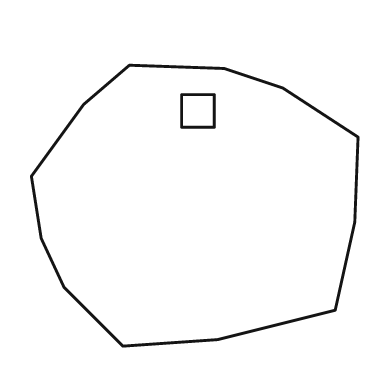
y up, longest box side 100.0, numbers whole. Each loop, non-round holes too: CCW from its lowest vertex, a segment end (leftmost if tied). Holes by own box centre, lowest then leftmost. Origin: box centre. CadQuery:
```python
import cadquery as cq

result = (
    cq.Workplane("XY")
    .moveTo(-22.0, -43.0)
    .lineTo(7.0, -41.0)
    .lineTo(43.0, -32.0)
    .lineTo(49.0, -5.0)
    .lineTo(50.0, 21.0)
    .lineTo(27.0, 36.0)
    .lineTo(9.0, 42.0)
    .lineTo(-20.0, 43.0)
    .lineTo(-34.0, 31.0)
    .lineTo(-50.0, 9.0)
    .lineTo(-47.0, -10.0)
    .lineTo(-40.0, -25.0)
    .close()
    .moveTo(-4.0, 24.0)
    .lineTo(6.0, 24.0)
    .lineTo(6.0, 34.0)
    .lineTo(-4.0, 34.0)
    .close()
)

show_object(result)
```